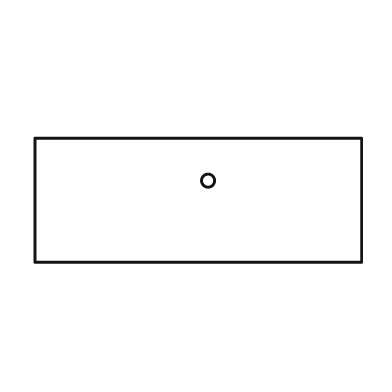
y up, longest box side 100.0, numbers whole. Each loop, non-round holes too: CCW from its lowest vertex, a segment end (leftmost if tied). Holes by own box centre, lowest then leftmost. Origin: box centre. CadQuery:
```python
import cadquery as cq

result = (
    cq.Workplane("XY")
    .moveTo(-50.0, -19.0)
    .lineTo(50.0, -19.0)
    .lineTo(50.0, 19.0)
    .lineTo(-50.0, 19.0)
    .close()
    .moveTo(3.0, 6.0)
    .circle(2.0)
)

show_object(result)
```